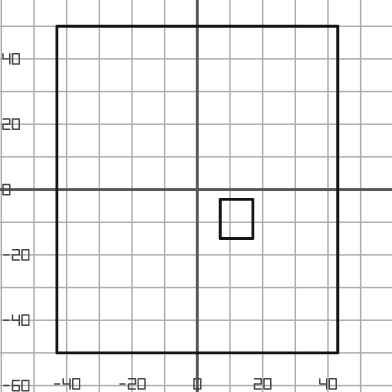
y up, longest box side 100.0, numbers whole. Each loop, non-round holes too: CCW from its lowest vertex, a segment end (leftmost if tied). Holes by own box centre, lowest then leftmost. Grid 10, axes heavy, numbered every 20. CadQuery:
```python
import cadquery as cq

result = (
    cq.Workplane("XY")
    .moveTo(-43.0, -50.0)
    .lineTo(43.0, -50.0)
    .lineTo(43.0, 50.0)
    .lineTo(-43.0, 50.0)
    .close()
    .moveTo(7.0, -15.0)
    .lineTo(17.0, -15.0)
    .lineTo(17.0, -3.0)
    .lineTo(7.0, -3.0)
    .close()
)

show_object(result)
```